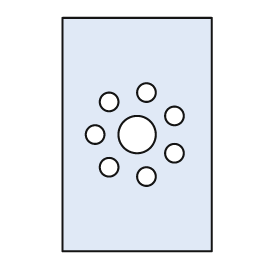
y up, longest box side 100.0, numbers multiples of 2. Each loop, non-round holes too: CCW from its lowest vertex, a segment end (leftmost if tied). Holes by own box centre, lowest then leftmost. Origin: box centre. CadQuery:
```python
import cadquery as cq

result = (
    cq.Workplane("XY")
    .moveTo(-32.0, -50.0)
    .lineTo(32.0, -50.0)
    .lineTo(32.0, 50.0)
    .lineTo(-32.0, 50.0)
    .close()
    .moveTo(4.0, -18.0)
    .circle(4.0)
    .moveTo(-12.0, -14.0)
    .circle(4.0)
    .moveTo(16.0, -8.0)
    .circle(4.0)
    .moveTo(-18.0, 0.0)
    .circle(4.0)
    .moveTo(0.0, 0.0)
    .circle(8.0)
    .moveTo(16.0, 8.0)
    .circle(4.0)
    .moveTo(-12.0, 14.0)
    .circle(4.0)
    .moveTo(4.0, 18.0)
    .circle(4.0)
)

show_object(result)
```